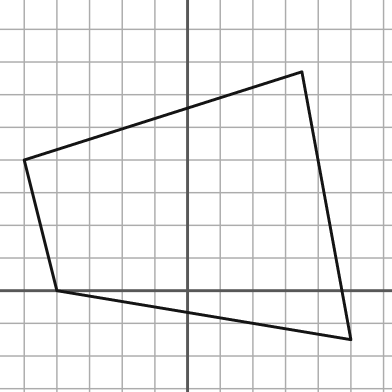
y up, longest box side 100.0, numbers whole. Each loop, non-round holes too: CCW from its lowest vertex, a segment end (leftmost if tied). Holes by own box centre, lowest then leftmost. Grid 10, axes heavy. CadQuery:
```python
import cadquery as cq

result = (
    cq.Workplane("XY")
    .moveTo(50.0, -15.0)
    .lineTo(35.0, 67.0)
    .lineTo(-50.0, 40.0)
    .lineTo(-40.0, 0.0)
    .close()
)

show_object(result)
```